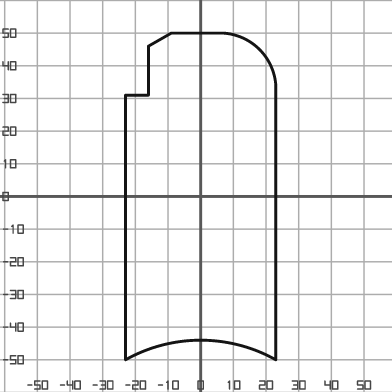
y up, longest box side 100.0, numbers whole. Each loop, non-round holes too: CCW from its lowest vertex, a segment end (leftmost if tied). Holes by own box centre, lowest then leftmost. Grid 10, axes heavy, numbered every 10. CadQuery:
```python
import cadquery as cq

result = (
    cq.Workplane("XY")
    .moveTo(-23.0, -50.0)
    .threePointArc((0.0, -44.0), (23.0, -50.0))
    .lineTo(23.0, 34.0)
    .threePointArc((18.0, 45.0), (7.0, 50.0))
    .lineTo(-9.0, 50.0)
    .lineTo(-16.0, 46.0)
    .lineTo(-16.0, 31.0)
    .lineTo(-23.0, 31.0)
    .close()
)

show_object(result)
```